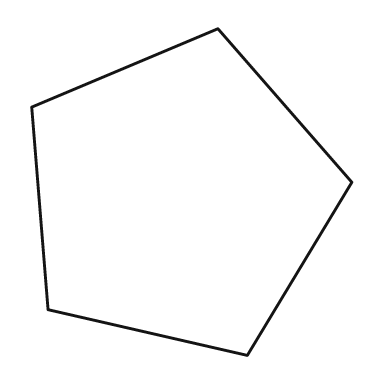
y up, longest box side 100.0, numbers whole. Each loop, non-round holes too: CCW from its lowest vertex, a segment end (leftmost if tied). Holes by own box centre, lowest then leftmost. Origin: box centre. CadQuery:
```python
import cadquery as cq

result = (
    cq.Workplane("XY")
    .moveTo(17.0, -50.0)
    .lineTo(49.0, 3.0)
    .lineTo(8.0, 50.0)
    .lineTo(-49.0, 26.0)
    .lineTo(-44.0, -36.0)
    .close()
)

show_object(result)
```